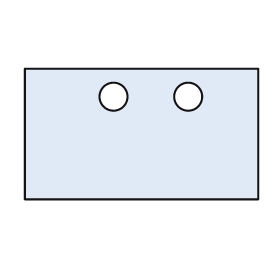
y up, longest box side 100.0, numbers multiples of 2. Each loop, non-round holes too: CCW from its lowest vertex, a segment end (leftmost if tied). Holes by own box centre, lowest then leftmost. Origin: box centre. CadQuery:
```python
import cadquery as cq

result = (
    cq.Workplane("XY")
    .moveTo(-50.0, -28.0)
    .lineTo(50.0, -28.0)
    .lineTo(50.0, 28.0)
    .lineTo(-50.0, 28.0)
    .close()
    .moveTo(-12.0, 16.0)
    .circle(6.0)
    .moveTo(20.0, 16.0)
    .circle(6.0)
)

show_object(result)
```